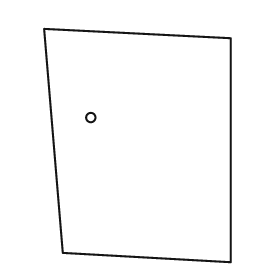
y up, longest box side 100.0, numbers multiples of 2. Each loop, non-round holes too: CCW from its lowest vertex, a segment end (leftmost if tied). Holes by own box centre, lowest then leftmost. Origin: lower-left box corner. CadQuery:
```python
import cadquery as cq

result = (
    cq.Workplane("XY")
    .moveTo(80.0, 0.0)
    .lineTo(80.0, 96.0)
    .lineTo(0.0, 100.0)
    .lineTo(8.0, 4.0)
    .close()
    .moveTo(20.0, 62.0)
    .circle(2.0)
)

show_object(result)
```